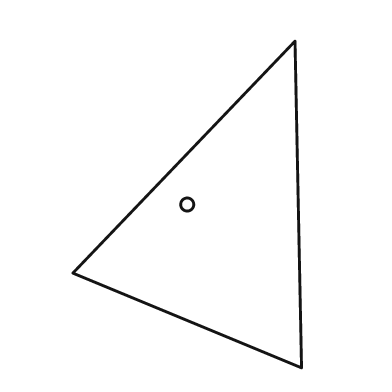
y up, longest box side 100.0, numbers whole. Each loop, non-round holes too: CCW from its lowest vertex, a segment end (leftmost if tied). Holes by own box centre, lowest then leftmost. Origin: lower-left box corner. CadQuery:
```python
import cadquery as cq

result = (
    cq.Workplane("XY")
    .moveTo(70.0, 0.0)
    .lineTo(68.0, 100.0)
    .lineTo(0.0, 29.0)
    .close()
    .moveTo(35.0, 50.0)
    .circle(2.0)
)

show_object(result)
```